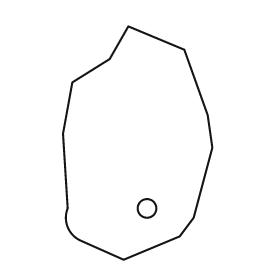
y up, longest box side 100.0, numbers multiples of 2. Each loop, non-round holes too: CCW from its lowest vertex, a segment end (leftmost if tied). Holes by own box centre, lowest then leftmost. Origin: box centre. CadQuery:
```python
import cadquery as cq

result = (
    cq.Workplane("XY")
    .moveTo(-6.0, -50.0)
    .lineTo(18.0, -40.0)
    .lineTo(24.0, -32.0)
    .lineTo(32.0, -2.0)
    .lineTo(30.0, 12.0)
    .lineTo(20.0, 40.0)
    .lineTo(-4.0, 50.0)
    .lineTo(-12.0, 36.0)
    .lineTo(-28.0, 26.0)
    .lineTo(-32.0, 4.0)
    .lineTo(-30.0, -28.0)
    .threePointArc((-30.0, -36.0), (-24.0, -42.0))
    .close()
    .moveTo(4.0, -28.0)
    .circle(4.0)
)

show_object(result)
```